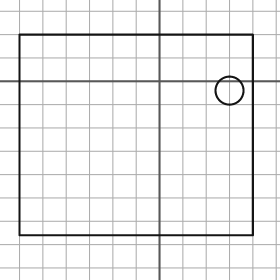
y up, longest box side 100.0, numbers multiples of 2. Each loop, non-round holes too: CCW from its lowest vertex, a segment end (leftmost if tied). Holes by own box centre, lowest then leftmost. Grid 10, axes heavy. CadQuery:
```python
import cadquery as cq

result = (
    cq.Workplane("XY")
    .moveTo(-60.0, -66.0)
    .lineTo(40.0, -66.0)
    .lineTo(40.0, 20.0)
    .lineTo(-60.0, 20.0)
    .close()
    .moveTo(30.0, -4.0)
    .circle(6.0)
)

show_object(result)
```